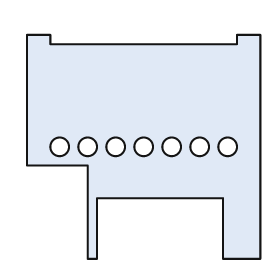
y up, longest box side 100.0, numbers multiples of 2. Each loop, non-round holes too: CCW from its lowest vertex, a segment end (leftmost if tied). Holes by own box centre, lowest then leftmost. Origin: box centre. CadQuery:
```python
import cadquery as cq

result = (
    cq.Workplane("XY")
    .moveTo(-24.0, -48.0)
    .lineTo(-20.0, -48.0)
    .lineTo(-20.0, -22.0)
    .lineTo(34.0, -22.0)
    .lineTo(34.0, -48.0)
    .lineTo(50.0, -48.0)
    .lineTo(50.0, 48.0)
    .lineTo(40.0, 48.0)
    .lineTo(40.0, 44.0)
    .lineTo(-40.0, 44.0)
    .lineTo(-40.0, 48.0)
    .lineTo(-50.0, 48.0)
    .lineTo(-50.0, -8.0)
    .lineTo(-24.0, -8.0)
    .close()
    .moveTo(-36.0, 0.0)
    .circle(4.0)
    .moveTo(-24.0, 0.0)
    .circle(4.0)
    .moveTo(-12.0, 0.0)
    .circle(4.0)
    .moveTo(0.0, 0.0)
    .circle(4.0)
    .moveTo(12.0, 0.0)
    .circle(4.0)
    .moveTo(24.0, 0.0)
    .circle(4.0)
    .moveTo(36.0, 0.0)
    .circle(4.0)
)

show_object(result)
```